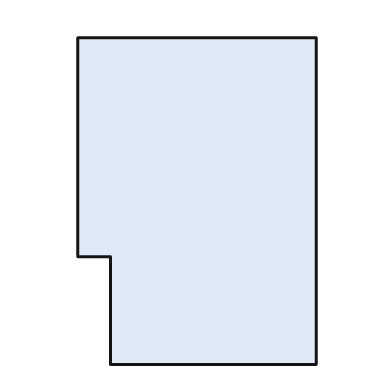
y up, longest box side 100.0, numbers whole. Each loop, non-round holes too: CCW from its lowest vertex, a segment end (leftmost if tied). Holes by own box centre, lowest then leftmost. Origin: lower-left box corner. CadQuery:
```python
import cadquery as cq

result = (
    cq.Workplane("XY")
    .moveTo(10.0, 0.0)
    .lineTo(73.0, 0.0)
    .lineTo(73.0, 100.0)
    .lineTo(0.0, 100.0)
    .lineTo(0.0, 33.0)
    .lineTo(10.0, 33.0)
    .close()
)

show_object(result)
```